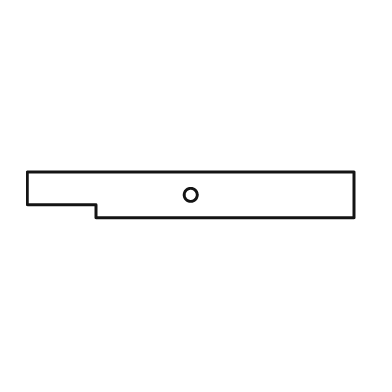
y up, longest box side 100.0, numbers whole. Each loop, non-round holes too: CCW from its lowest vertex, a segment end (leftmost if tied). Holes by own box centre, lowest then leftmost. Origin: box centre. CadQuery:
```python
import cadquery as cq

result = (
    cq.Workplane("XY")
    .moveTo(-29.0, -7.0)
    .lineTo(50.0, -7.0)
    .lineTo(50.0, 7.0)
    .lineTo(-50.0, 7.0)
    .lineTo(-50.0, -3.0)
    .lineTo(-29.0, -3.0)
    .close()
    .moveTo(0.0, 0.0)
    .circle(2.0)
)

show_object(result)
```